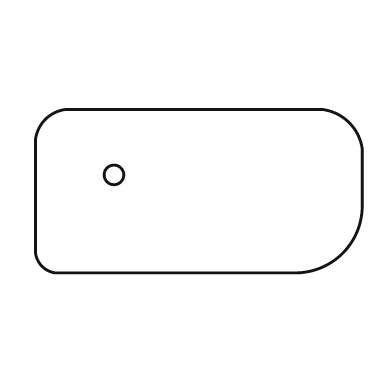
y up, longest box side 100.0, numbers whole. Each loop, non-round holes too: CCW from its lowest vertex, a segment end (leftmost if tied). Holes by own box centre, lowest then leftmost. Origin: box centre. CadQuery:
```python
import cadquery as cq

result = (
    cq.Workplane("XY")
    .moveTo(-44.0, -25.0)
    .lineTo(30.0, -25.0)
    .threePointArc((44.0, -19.0), (50.0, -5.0))
    .lineTo(50.0, 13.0)
    .threePointArc((46.0, 21.0), (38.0, 25.0))
    .lineTo(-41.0, 25.0)
    .threePointArc((-47.0, 22.0), (-50.0, 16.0))
    .lineTo(-50.0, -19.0)
    .threePointArc((-48.0, -23.0), (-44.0, -25.0))
    .close()
    .moveTo(-26.0, 5.0)
    .circle(3.0)
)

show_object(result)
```